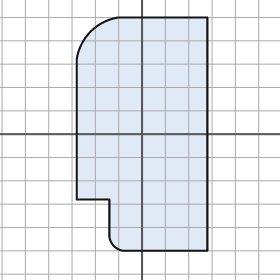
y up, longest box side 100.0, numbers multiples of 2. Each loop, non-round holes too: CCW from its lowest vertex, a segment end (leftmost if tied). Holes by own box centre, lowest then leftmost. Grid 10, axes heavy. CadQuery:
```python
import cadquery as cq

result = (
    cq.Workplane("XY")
    .moveTo(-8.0, -50.0)
    .lineTo(28.0, -50.0)
    .lineTo(28.0, 50.0)
    .lineTo(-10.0, 50.0)
    .threePointArc((-22.0, 44.0), (-28.0, 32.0))
    .lineTo(-28.0, -28.0)
    .lineTo(-14.0, -28.0)
    .lineTo(-14.0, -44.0)
    .threePointArc((-12.0, -48.0), (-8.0, -50.0))
    .close()
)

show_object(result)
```